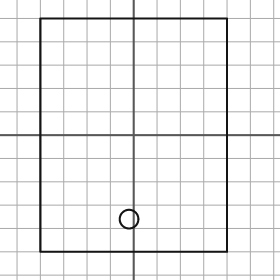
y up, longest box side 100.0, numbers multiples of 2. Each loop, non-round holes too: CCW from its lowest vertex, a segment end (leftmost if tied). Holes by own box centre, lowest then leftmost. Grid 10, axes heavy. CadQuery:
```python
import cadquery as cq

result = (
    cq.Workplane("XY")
    .moveTo(-40.0, -50.0)
    .lineTo(40.0, -50.0)
    .lineTo(40.0, 50.0)
    .lineTo(-40.0, 50.0)
    .close()
    .moveTo(-2.0, -36.0)
    .circle(4.0)
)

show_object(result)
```